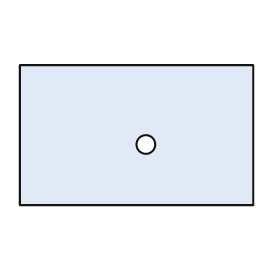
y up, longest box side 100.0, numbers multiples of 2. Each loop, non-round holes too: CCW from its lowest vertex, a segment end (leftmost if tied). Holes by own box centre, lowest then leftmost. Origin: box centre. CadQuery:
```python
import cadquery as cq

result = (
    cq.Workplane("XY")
    .moveTo(-50.0, -30.0)
    .lineTo(50.0, -30.0)
    .lineTo(50.0, 30.0)
    .lineTo(-50.0, 30.0)
    .close()
    .moveTo(4.0, -4.0)
    .circle(4.0)
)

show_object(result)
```